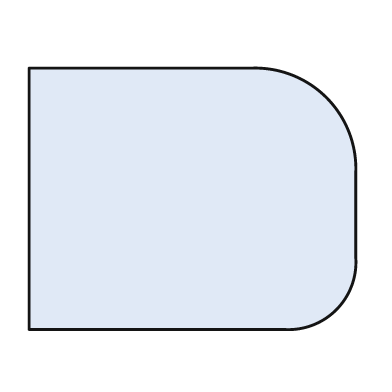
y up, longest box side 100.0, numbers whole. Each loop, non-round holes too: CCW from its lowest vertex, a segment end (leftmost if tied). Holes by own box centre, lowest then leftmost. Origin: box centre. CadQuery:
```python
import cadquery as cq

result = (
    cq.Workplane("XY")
    .moveTo(-50.0, -40.0)
    .lineTo(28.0, -40.0)
    .threePointArc((44.0, -34.0), (50.0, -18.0))
    .lineTo(50.0, 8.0)
    .threePointArc((41.0, 31.0), (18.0, 40.0))
    .lineTo(-50.0, 40.0)
    .close()
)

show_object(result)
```